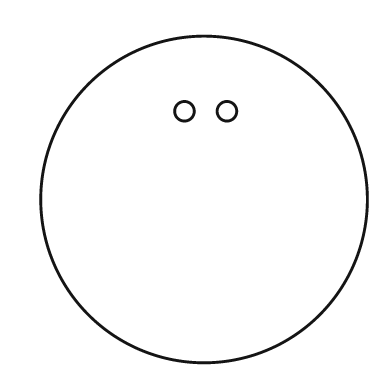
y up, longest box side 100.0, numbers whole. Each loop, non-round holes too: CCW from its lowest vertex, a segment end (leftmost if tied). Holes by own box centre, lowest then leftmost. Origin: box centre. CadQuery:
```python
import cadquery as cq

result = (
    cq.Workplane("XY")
    .moveTo(0.0, 0.0)
    .circle(50.0)
    .moveTo(-6.0, 27.0)
    .circle(3.0)
    .moveTo(7.0, 27.0)
    .circle(3.0)
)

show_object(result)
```